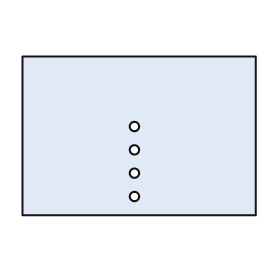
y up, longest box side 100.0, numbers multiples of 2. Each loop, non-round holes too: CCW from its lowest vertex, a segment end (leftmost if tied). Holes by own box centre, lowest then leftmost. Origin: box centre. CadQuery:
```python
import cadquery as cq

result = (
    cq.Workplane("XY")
    .moveTo(-50.0, -34.0)
    .lineTo(50.0, -34.0)
    .lineTo(50.0, 34.0)
    .lineTo(-50.0, 34.0)
    .close()
    .moveTo(-2.0, -26.0)
    .circle(2.0)
    .moveTo(-2.0, -16.0)
    .circle(2.0)
    .moveTo(-2.0, -6.0)
    .circle(2.0)
    .moveTo(-2.0, 4.0)
    .circle(2.0)
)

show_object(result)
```